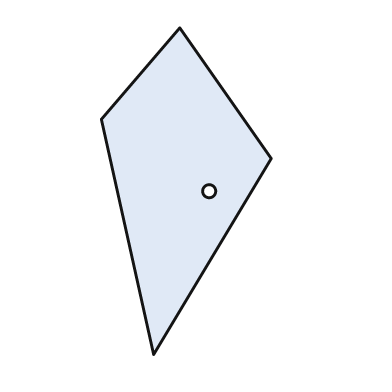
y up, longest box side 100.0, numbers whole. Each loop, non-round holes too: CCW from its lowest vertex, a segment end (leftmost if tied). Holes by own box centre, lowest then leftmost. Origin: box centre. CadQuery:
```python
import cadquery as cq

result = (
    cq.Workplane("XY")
    .moveTo(-10.0, -50.0)
    .lineTo(26.0, 10.0)
    .lineTo(-2.0, 50.0)
    .lineTo(-26.0, 22.0)
    .close()
    .moveTo(7.0, 0.0)
    .circle(2.0)
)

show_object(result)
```